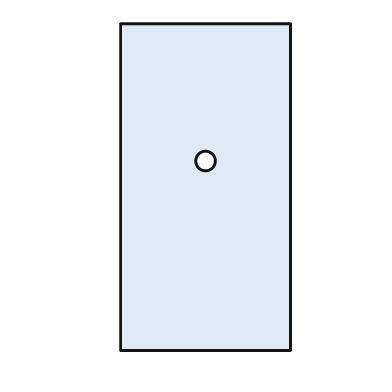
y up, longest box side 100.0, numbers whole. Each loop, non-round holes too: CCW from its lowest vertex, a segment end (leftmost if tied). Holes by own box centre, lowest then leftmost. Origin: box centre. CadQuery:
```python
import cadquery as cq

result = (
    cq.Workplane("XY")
    .moveTo(-26.0, -50.0)
    .lineTo(26.0, -50.0)
    .lineTo(26.0, 50.0)
    .lineTo(-26.0, 50.0)
    .close()
    .moveTo(0.0, 8.0)
    .circle(3.0)
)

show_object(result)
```